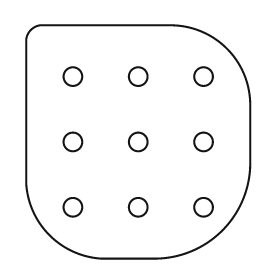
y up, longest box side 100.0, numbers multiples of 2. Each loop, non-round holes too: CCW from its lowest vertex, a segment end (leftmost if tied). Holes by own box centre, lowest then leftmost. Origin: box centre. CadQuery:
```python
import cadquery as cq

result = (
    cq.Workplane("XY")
    .moveTo(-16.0, -50.0)
    .lineTo(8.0, -50.0)
    .threePointArc((36.0, -38.0), (48.0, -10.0))
    .lineTo(48.0, 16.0)
    .threePointArc((38.0, 40.0), (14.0, 50.0))
    .lineTo(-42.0, 50.0)
    .threePointArc((-46.0, 48.0), (-48.0, 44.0))
    .lineTo(-48.0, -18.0)
    .threePointArc((-38.0, -40.0), (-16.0, -50.0))
    .close()
    .moveTo(-28.0, -28.0)
    .circle(4.0)
    .moveTo(0.0, -28.0)
    .circle(4.0)
    .moveTo(28.0, -28.0)
    .circle(4.0)
    .moveTo(-28.0, 0.0)
    .circle(4.0)
    .moveTo(0.0, 0.0)
    .circle(4.0)
    .moveTo(28.0, 0.0)
    .circle(4.0)
    .moveTo(-28.0, 28.0)
    .circle(4.0)
    .moveTo(0.0, 28.0)
    .circle(4.0)
    .moveTo(28.0, 28.0)
    .circle(4.0)
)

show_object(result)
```